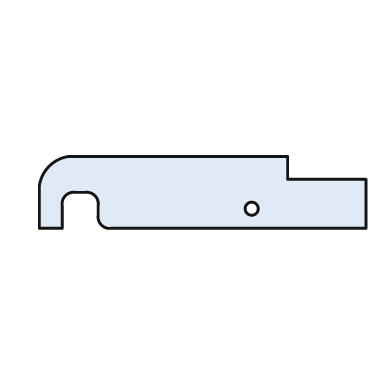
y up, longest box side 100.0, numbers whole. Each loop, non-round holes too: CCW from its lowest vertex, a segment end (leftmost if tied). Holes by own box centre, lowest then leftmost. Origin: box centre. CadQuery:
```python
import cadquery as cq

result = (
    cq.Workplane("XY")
    .moveTo(-50.0, -11.0)
    .lineTo(-43.0, -11.0)
    .lineTo(-43.0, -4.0)
    .threePointArc((-42.0, -1.0), (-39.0, 0.0))
    .lineTo(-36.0, 0.0)
    .threePointArc((-33.0, -1.0), (-32.0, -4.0))
    .lineTo(-32.0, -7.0)
    .threePointArc((-31.0, -10.0), (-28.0, -11.0))
    .lineTo(50.0, -11.0)
    .lineTo(50.0, 4.0)
    .lineTo(26.0, 4.0)
    .lineTo(26.0, 11.0)
    .lineTo(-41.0, 11.0)
    .threePointArc((-47.0, 8.0), (-50.0, 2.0))
    .close()
    .moveTo(15.0, -5.0)
    .circle(2.0)
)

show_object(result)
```